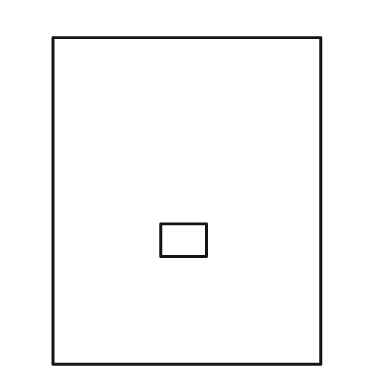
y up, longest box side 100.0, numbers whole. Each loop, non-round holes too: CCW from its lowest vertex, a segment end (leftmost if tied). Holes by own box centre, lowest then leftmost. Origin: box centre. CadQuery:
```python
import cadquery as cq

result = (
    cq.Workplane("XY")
    .moveTo(-41.0, -50.0)
    .lineTo(41.0, -50.0)
    .lineTo(41.0, 50.0)
    .lineTo(-41.0, 50.0)
    .close()
    .moveTo(-8.0, -17.0)
    .lineTo(6.0, -17.0)
    .lineTo(6.0, -7.0)
    .lineTo(-8.0, -7.0)
    .close()
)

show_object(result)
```